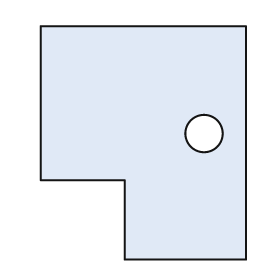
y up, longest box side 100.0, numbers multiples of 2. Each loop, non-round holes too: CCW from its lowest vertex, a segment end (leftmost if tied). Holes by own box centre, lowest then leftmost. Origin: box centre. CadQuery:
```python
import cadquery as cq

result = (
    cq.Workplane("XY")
    .moveTo(-8.0, -50.0)
    .lineTo(44.0, -50.0)
    .lineTo(44.0, 50.0)
    .lineTo(-44.0, 50.0)
    .lineTo(-44.0, -16.0)
    .lineTo(-8.0, -16.0)
    .close()
    .moveTo(26.0, 4.0)
    .circle(8.0)
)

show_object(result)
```